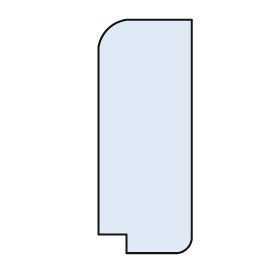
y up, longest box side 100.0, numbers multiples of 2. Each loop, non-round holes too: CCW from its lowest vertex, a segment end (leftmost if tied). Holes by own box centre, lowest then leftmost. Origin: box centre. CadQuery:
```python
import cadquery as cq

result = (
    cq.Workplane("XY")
    .moveTo(-8.0, -50.0)
    .lineTo(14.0, -50.0)
    .threePointArc((18.0, -48.0), (20.0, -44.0))
    .lineTo(20.0, 50.0)
    .lineTo(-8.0, 50.0)
    .threePointArc((-16.0, 46.0), (-20.0, 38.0))
    .lineTo(-20.0, -42.0)
    .lineTo(-8.0, -42.0)
    .close()
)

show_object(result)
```